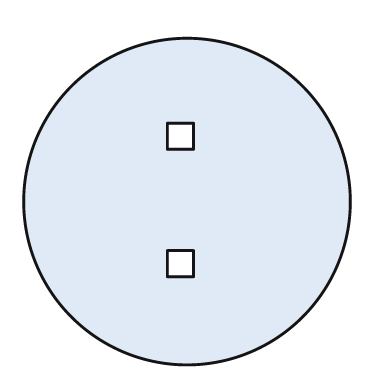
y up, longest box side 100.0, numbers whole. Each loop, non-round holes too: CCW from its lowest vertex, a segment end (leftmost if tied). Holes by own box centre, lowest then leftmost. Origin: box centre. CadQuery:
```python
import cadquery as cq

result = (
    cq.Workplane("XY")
    .moveTo(0.0, 0.0)
    .circle(50.0)
    .moveTo(-6.0, -23.0)
    .lineTo(2.0, -23.0)
    .lineTo(2.0, -15.0)
    .lineTo(-6.0, -15.0)
    .close()
    .moveTo(-6.0, 16.0)
    .lineTo(2.0, 16.0)
    .lineTo(2.0, 24.0)
    .lineTo(-6.0, 24.0)
    .close()
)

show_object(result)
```